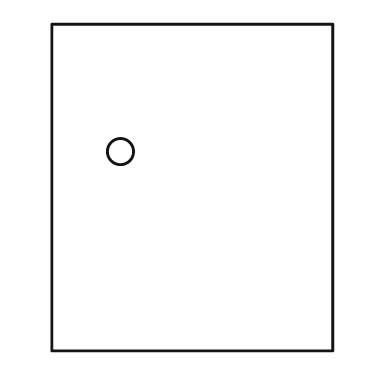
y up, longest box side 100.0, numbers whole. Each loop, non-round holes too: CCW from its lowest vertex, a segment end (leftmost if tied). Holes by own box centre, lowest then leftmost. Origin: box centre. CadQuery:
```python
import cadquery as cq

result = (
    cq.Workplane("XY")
    .moveTo(-43.0, -50.0)
    .lineTo(43.0, -50.0)
    .lineTo(43.0, 50.0)
    .lineTo(-43.0, 50.0)
    .close()
    .moveTo(-22.0, 11.0)
    .circle(4.0)
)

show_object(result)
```